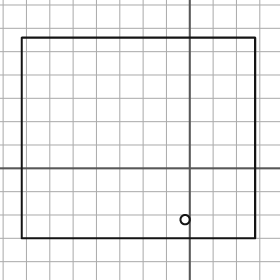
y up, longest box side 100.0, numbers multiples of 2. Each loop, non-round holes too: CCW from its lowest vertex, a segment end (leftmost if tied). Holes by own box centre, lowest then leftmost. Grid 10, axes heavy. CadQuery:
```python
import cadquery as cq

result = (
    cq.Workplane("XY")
    .moveTo(-72.0, -30.0)
    .lineTo(28.0, -30.0)
    .lineTo(28.0, 56.0)
    .lineTo(-72.0, 56.0)
    .close()
    .moveTo(-2.0, -22.0)
    .circle(2.0)
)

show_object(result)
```